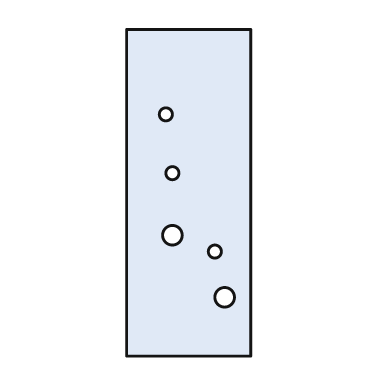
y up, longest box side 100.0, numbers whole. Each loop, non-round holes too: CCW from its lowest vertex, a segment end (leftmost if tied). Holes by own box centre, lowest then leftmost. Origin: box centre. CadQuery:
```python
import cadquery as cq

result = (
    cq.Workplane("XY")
    .moveTo(-19.0, -50.0)
    .lineTo(19.0, -50.0)
    .lineTo(19.0, 50.0)
    .lineTo(-19.0, 50.0)
    .close()
    .moveTo(11.0, -32.0)
    .circle(3.0)
    .moveTo(8.0, -18.0)
    .circle(2.0)
    .moveTo(-5.0, -13.0)
    .circle(3.0)
    .moveTo(-5.0, 6.0)
    .circle(2.0)
    .moveTo(-7.0, 24.0)
    .circle(2.0)
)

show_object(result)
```